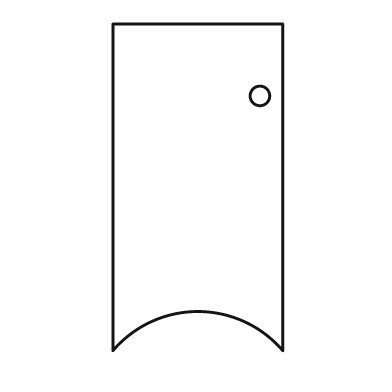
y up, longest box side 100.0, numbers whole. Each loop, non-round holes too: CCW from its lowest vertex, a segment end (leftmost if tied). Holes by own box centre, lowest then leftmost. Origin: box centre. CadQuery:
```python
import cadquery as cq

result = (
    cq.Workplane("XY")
    .moveTo(-26.0, -50.0)
    .threePointArc((0.0, -38.0), (26.0, -50.0))
    .lineTo(26.0, 50.0)
    .lineTo(-26.0, 50.0)
    .close()
    .moveTo(19.0, 28.0)
    .circle(3.0)
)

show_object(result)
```